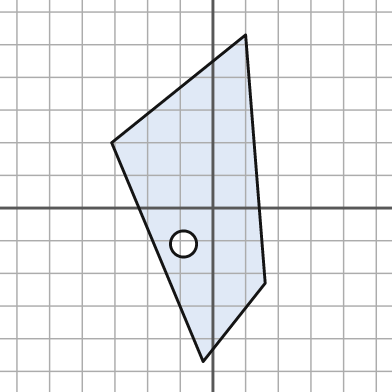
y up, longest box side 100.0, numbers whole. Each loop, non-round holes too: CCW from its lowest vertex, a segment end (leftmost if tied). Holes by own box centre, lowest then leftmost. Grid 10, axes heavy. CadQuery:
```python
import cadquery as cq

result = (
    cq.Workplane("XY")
    .moveTo(-3.0, -47.0)
    .lineTo(16.0, -23.0)
    .lineTo(10.0, 53.0)
    .lineTo(-31.0, 20.0)
    .close()
    .moveTo(-9.0, -11.0)
    .circle(4.0)
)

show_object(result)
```